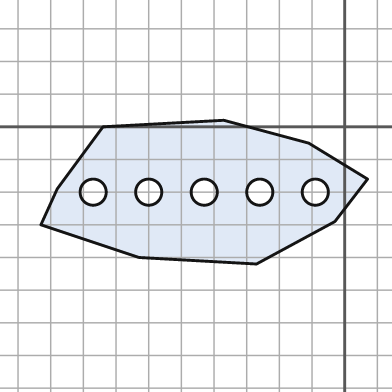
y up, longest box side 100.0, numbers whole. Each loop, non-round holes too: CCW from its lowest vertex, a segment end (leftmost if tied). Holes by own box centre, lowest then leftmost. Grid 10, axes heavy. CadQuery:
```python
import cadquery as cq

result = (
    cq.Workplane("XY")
    .moveTo(-27.0, -42.0)
    .lineTo(-3.0, -29.0)
    .lineTo(7.0, -16.0)
    .lineTo(-11.0, -5.0)
    .lineTo(-37.0, 2.0)
    .lineTo(-74.0, 0.0)
    .lineTo(-88.0, -19.0)
    .lineTo(-93.0, -30.0)
    .lineTo(-63.0, -40.0)
    .close()
    .moveTo(-77.0, -20.0)
    .circle(4.0)
    .moveTo(-60.0, -20.0)
    .circle(4.0)
    .moveTo(-43.0, -20.0)
    .circle(4.0)
    .moveTo(-26.0, -20.0)
    .circle(4.0)
    .moveTo(-9.0, -20.0)
    .circle(4.0)
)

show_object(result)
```